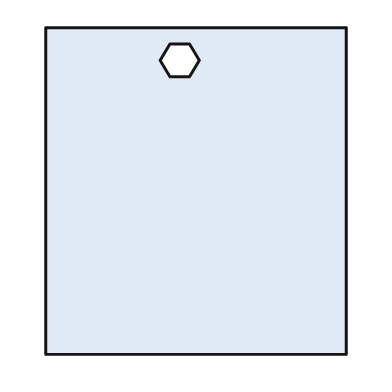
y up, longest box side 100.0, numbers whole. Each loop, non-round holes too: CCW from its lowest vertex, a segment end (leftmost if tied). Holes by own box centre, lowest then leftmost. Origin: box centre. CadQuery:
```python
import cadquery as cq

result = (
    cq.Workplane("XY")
    .moveTo(-46.0, -50.0)
    .lineTo(46.0, -50.0)
    .lineTo(46.0, 50.0)
    .lineTo(-46.0, 50.0)
    .close()
    .moveTo(-8.0, 35.0)
    .lineTo(-2.0, 35.0)
    .lineTo(1.0, 40.0)
    .lineTo(-2.0, 45.0)
    .lineTo(-8.0, 45.0)
    .lineTo(-11.0, 40.0)
    .close()
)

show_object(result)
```